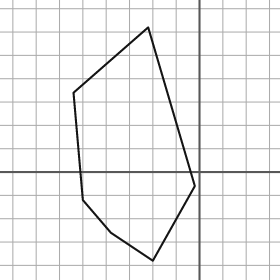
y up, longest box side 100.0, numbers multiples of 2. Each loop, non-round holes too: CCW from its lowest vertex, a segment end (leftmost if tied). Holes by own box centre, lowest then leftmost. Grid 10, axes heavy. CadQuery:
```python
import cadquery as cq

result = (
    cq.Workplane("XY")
    .moveTo(-20.0, -38.0)
    .lineTo(-2.0, -6.0)
    .lineTo(-22.0, 62.0)
    .lineTo(-54.0, 34.0)
    .lineTo(-50.0, -12.0)
    .lineTo(-38.0, -26.0)
    .close()
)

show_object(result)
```